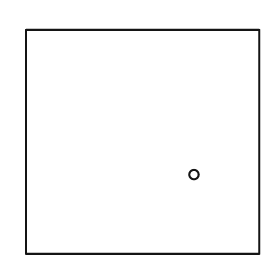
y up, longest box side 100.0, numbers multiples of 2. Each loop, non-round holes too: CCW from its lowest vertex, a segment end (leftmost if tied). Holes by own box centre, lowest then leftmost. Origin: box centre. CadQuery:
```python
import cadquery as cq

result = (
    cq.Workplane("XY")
    .moveTo(-50.0, -48.0)
    .lineTo(50.0, -48.0)
    .lineTo(50.0, 48.0)
    .lineTo(-50.0, 48.0)
    .close()
    .moveTo(22.0, -14.0)
    .circle(2.0)
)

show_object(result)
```